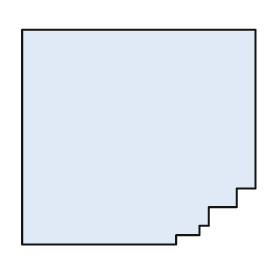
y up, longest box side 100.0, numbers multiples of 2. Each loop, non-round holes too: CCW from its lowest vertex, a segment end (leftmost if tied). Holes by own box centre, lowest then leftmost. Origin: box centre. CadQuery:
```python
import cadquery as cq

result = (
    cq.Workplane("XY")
    .moveTo(-50.0, -46.0)
    .lineTo(16.0, -46.0)
    .lineTo(16.0, -42.0)
    .lineTo(26.0, -42.0)
    .lineTo(26.0, -38.0)
    .lineTo(30.0, -38.0)
    .lineTo(30.0, -30.0)
    .lineTo(42.0, -30.0)
    .lineTo(42.0, -22.0)
    .lineTo(50.0, -22.0)
    .lineTo(50.0, 46.0)
    .lineTo(-50.0, 46.0)
    .close()
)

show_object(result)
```